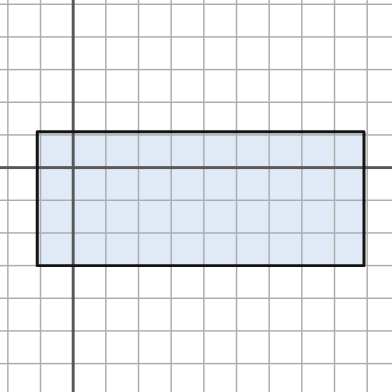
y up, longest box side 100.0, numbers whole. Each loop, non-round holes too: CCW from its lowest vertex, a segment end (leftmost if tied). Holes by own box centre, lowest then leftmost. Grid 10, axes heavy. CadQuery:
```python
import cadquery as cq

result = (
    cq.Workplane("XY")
    .moveTo(-11.0, -30.0)
    .lineTo(89.0, -30.0)
    .lineTo(89.0, 11.0)
    .lineTo(-11.0, 11.0)
    .close()
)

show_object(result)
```